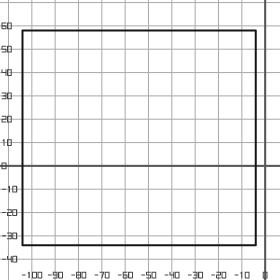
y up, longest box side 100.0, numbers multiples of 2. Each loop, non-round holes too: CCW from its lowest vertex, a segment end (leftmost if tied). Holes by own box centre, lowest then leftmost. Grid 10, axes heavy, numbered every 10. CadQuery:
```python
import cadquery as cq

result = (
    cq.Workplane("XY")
    .moveTo(-104.0, -34.0)
    .lineTo(-4.0, -34.0)
    .lineTo(-4.0, 58.0)
    .lineTo(-104.0, 58.0)
    .close()
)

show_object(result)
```